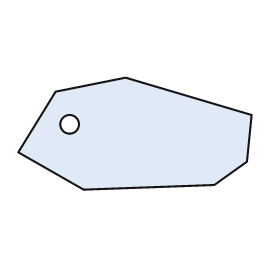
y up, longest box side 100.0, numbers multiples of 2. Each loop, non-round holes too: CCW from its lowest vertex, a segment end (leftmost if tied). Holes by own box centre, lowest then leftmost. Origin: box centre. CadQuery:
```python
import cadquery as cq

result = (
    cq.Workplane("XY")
    .moveTo(-22.0, -24.0)
    .lineTo(34.0, -22.0)
    .lineTo(48.0, -12.0)
    .lineTo(50.0, 8.0)
    .lineTo(-4.0, 24.0)
    .lineTo(-34.0, 18.0)
    .lineTo(-50.0, -8.0)
    .close()
    .moveTo(-28.0, 4.0)
    .circle(4.0)
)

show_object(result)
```